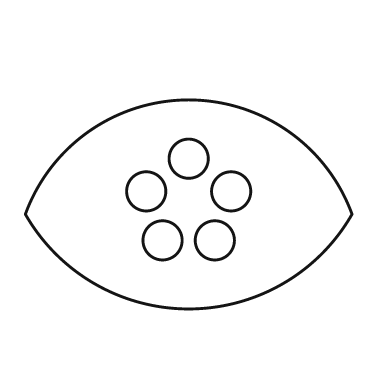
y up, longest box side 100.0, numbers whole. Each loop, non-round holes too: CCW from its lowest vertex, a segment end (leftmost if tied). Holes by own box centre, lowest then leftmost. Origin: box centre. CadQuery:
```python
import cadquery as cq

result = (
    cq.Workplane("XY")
    .moveTo(-50.0, -3.0)
    .threePointArc((0.0, -32.0), (50.0, -3.0))
    .threePointArc((0.0, 32.0), (-50.0, -3.0))
    .close()
    .moveTo(-8.0, -11.0)
    .circle(6.0)
    .moveTo(8.0, -11.0)
    .circle(6.0)
    .moveTo(-13.0, 4.0)
    .circle(6.0)
    .moveTo(13.0, 4.0)
    .circle(6.0)
    .moveTo(0.0, 14.0)
    .circle(6.0)
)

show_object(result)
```